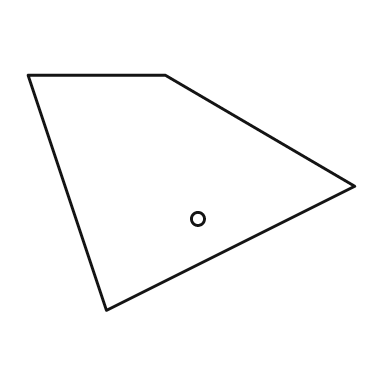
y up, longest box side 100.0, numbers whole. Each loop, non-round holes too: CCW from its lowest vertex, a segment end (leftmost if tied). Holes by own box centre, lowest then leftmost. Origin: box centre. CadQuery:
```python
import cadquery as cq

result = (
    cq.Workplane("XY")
    .moveTo(-26.0, -36.0)
    .lineTo(50.0, 2.0)
    .lineTo(-8.0, 36.0)
    .lineTo(-50.0, 36.0)
    .close()
    .moveTo(2.0, -8.0)
    .circle(2.0)
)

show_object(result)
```